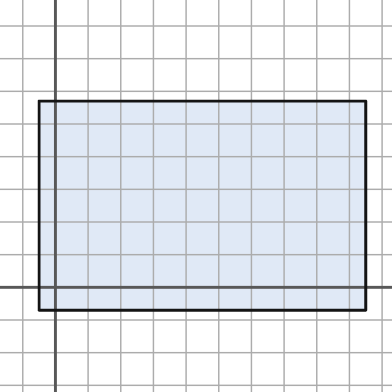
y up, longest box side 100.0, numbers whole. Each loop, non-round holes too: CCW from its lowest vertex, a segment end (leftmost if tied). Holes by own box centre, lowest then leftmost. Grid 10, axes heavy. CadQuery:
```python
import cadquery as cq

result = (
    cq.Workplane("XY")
    .moveTo(-5.0, -7.0)
    .lineTo(95.0, -7.0)
    .lineTo(95.0, 57.0)
    .lineTo(-5.0, 57.0)
    .close()
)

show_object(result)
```